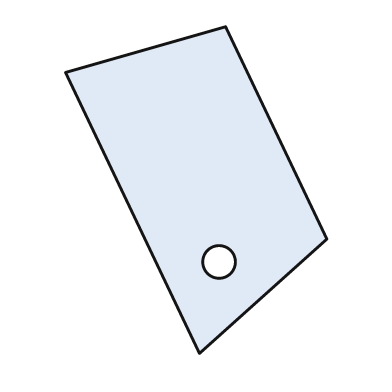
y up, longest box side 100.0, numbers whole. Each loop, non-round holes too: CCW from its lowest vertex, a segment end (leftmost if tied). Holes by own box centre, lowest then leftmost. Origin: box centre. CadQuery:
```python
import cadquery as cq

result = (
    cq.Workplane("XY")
    .moveTo(1.0, -50.0)
    .lineTo(40.0, -15.0)
    .lineTo(9.0, 50.0)
    .lineTo(-40.0, 36.0)
    .close()
    .moveTo(7.0, -22.0)
    .circle(5.0)
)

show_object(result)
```